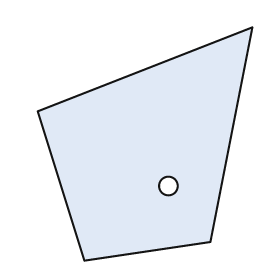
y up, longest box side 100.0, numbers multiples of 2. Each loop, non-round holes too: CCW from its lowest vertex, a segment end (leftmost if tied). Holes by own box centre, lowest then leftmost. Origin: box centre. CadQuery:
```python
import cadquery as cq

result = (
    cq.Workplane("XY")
    .moveTo(-26.0, -50.0)
    .lineTo(28.0, -42.0)
    .lineTo(46.0, 50.0)
    .lineTo(-46.0, 14.0)
    .close()
    .moveTo(10.0, -18.0)
    .circle(4.0)
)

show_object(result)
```